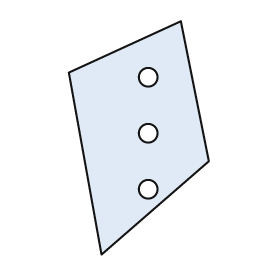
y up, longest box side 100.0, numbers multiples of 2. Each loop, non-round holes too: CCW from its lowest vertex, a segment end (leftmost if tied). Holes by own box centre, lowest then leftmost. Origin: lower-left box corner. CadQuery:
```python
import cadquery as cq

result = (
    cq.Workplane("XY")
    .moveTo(14.0, 0.0)
    .lineTo(60.0, 40.0)
    .lineTo(48.0, 100.0)
    .lineTo(0.0, 78.0)
    .close()
    .moveTo(34.0, 28.0)
    .circle(4.0)
    .moveTo(34.0, 52.0)
    .circle(4.0)
    .moveTo(34.0, 76.0)
    .circle(4.0)
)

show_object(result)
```